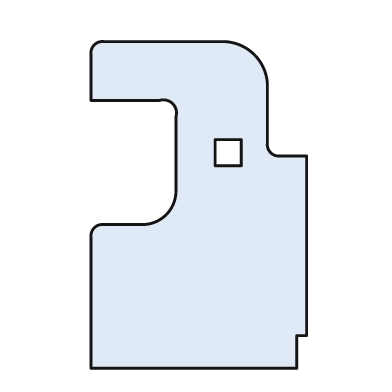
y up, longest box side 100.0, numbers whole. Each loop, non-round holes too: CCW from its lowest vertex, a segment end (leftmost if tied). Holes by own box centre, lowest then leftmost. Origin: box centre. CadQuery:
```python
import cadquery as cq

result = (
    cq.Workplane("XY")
    .moveTo(-33.0, -50.0)
    .lineTo(30.0, -50.0)
    .lineTo(30.0, -40.0)
    .lineTo(33.0, -40.0)
    .lineTo(33.0, 15.0)
    .lineTo(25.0, 15.0)
    .threePointArc((22.0, 16.0), (21.0, 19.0))
    .lineTo(21.0, 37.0)
    .threePointArc((17.0, 46.0), (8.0, 50.0))
    .lineTo(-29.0, 50.0)
    .threePointArc((-32.0, 49.0), (-33.0, 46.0))
    .lineTo(-33.0, 32.0)
    .lineTo(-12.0, 32.0)
    .threePointArc((-8.0, 31.0), (-7.0, 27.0))
    .lineTo(-7.0, 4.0)
    .threePointArc((-10.0, -3.0), (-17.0, -6.0))
    .lineTo(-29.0, -6.0)
    .threePointArc((-32.0, -7.0), (-33.0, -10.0))
    .close()
    .moveTo(5.0, 12.0)
    .lineTo(13.0, 12.0)
    .lineTo(13.0, 20.0)
    .lineTo(5.0, 20.0)
    .close()
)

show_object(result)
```